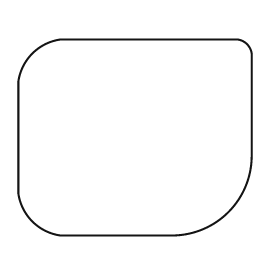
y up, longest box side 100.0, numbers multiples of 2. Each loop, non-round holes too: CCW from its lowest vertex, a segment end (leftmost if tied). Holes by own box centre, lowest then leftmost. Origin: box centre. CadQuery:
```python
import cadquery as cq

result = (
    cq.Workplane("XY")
    .moveTo(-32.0, -42.0)
    .lineTo(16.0, -42.0)
    .threePointArc((40.0, -32.0), (50.0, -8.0))
    .lineTo(50.0, 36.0)
    .threePointArc((48.0, 40.0), (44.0, 42.0))
    .lineTo(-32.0, 42.0)
    .threePointArc((-44.0, 36.0), (-50.0, 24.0))
    .lineTo(-50.0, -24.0)
    .threePointArc((-44.0, -36.0), (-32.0, -42.0))
    .close()
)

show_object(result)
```